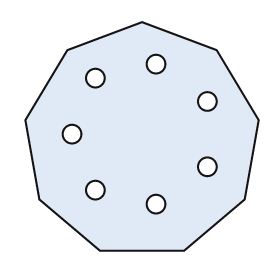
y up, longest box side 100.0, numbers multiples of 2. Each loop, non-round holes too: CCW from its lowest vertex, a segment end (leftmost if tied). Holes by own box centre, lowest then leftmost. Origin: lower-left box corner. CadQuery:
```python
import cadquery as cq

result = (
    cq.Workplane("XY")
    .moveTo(32.0, 0.0)
    .lineTo(68.0, 0.0)
    .lineTo(94.0, 22.0)
    .lineTo(100.0, 56.0)
    .lineTo(82.0, 86.0)
    .lineTo(50.0, 98.0)
    .lineTo(18.0, 86.0)
    .lineTo(0.0, 56.0)
    .lineTo(6.0, 22.0)
    .close()
    .moveTo(56.0, 20.0)
    .circle(4.0)
    .moveTo(30.0, 26.0)
    .circle(4.0)
    .moveTo(78.0, 36.0)
    .circle(4.0)
    .moveTo(20.0, 50.0)
    .circle(4.0)
    .moveTo(78.0, 64.0)
    .circle(4.0)
    .moveTo(30.0, 74.0)
    .circle(4.0)
    .moveTo(56.0, 80.0)
    .circle(4.0)
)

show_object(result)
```